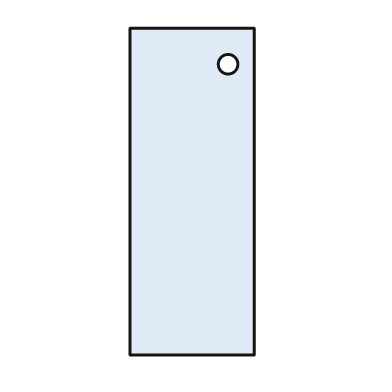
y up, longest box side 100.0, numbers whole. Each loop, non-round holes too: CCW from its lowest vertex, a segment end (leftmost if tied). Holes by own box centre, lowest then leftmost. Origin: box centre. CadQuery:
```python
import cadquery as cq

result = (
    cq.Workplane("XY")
    .moveTo(-19.0, -50.0)
    .lineTo(19.0, -50.0)
    .lineTo(19.0, 50.0)
    .lineTo(-19.0, 50.0)
    .close()
    .moveTo(11.0, 39.0)
    .circle(3.0)
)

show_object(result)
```